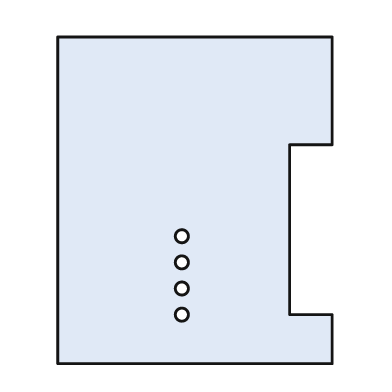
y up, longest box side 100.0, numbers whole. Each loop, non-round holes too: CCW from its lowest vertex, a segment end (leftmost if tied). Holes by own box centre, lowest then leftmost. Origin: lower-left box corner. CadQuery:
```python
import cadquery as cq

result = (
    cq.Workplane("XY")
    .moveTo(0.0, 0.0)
    .lineTo(84.0, 0.0)
    .lineTo(84.0, 15.0)
    .lineTo(71.0, 15.0)
    .lineTo(71.0, 67.0)
    .lineTo(84.0, 67.0)
    .lineTo(84.0, 100.0)
    .lineTo(0.0, 100.0)
    .close()
    .moveTo(38.0, 15.0)
    .circle(2.0)
    .moveTo(38.0, 23.0)
    .circle(2.0)
    .moveTo(38.0, 31.0)
    .circle(2.0)
    .moveTo(38.0, 39.0)
    .circle(2.0)
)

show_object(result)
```